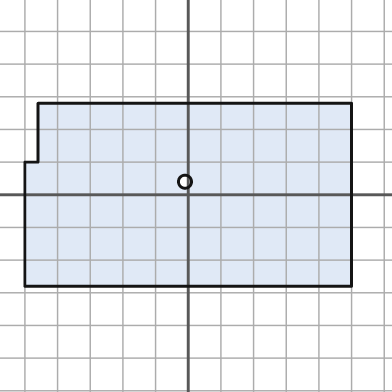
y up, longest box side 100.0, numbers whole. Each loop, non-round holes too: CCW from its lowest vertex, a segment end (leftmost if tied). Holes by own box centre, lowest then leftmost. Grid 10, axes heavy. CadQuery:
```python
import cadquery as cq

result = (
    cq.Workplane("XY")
    .moveTo(-50.0, -28.0)
    .lineTo(50.0, -28.0)
    .lineTo(50.0, 28.0)
    .lineTo(-46.0, 28.0)
    .lineTo(-46.0, 10.0)
    .lineTo(-50.0, 10.0)
    .close()
    .moveTo(-1.0, 4.0)
    .circle(2.0)
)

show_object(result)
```